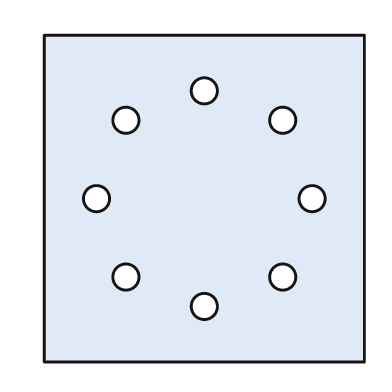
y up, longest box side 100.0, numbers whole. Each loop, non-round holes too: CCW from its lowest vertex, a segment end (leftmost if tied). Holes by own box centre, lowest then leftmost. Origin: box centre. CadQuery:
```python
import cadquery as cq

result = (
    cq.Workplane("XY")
    .moveTo(-49.0, -50.0)
    .lineTo(49.0, -50.0)
    .lineTo(49.0, 50.0)
    .lineTo(-49.0, 50.0)
    .close()
    .moveTo(0.0, -33.0)
    .circle(4.0)
    .moveTo(-24.0, -24.0)
    .circle(4.0)
    .moveTo(24.0, -24.0)
    .circle(4.0)
    .moveTo(-33.0, 0.0)
    .circle(4.0)
    .moveTo(33.0, 0.0)
    .circle(4.0)
    .moveTo(-24.0, 24.0)
    .circle(4.0)
    .moveTo(24.0, 24.0)
    .circle(4.0)
    .moveTo(0.0, 33.0)
    .circle(4.0)
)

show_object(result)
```